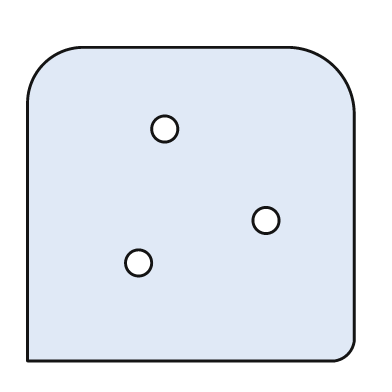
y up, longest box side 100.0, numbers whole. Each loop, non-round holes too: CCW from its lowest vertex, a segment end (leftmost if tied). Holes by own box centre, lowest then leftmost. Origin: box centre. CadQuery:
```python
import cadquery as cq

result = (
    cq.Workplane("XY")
    .moveTo(-50.0, -48.0)
    .lineTo(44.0, -48.0)
    .threePointArc((48.0, -46.0), (50.0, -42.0))
    .lineTo(50.0, 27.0)
    .threePointArc((44.0, 42.0), (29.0, 48.0))
    .lineTo(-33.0, 48.0)
    .threePointArc((-45.0, 43.0), (-50.0, 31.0))
    .close()
    .moveTo(-16.0, -18.0)
    .circle(4.0)
    .moveTo(23.0, -5.0)
    .circle(4.0)
    .moveTo(-8.0, 23.0)
    .circle(4.0)
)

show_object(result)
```